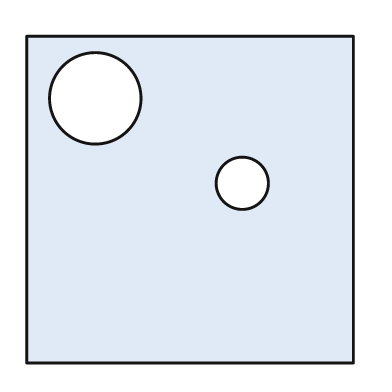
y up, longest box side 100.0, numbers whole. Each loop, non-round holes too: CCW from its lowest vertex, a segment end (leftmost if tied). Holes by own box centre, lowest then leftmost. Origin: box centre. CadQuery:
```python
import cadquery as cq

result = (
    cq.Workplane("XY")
    .moveTo(-50.0, -50.0)
    .lineTo(50.0, -50.0)
    .lineTo(50.0, 50.0)
    .lineTo(-50.0, 50.0)
    .close()
    .moveTo(16.0, 5.0)
    .circle(8.0)
    .moveTo(-29.0, 31.0)
    .circle(14.0)
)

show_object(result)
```